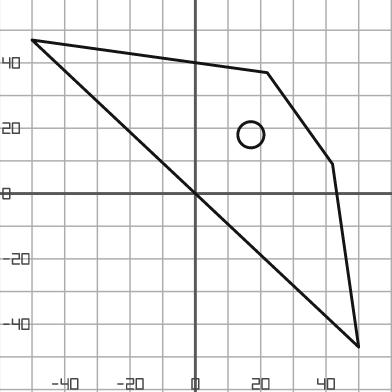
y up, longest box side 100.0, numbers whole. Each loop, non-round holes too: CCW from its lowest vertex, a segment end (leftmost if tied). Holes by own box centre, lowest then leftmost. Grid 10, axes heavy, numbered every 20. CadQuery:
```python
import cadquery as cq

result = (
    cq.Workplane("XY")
    .moveTo(50.0, -47.0)
    .lineTo(42.0, 9.0)
    .lineTo(22.0, 37.0)
    .lineTo(-50.0, 47.0)
    .close()
    .moveTo(17.0, 18.0)
    .circle(4.0)
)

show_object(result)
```